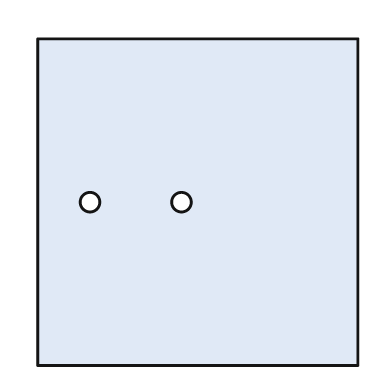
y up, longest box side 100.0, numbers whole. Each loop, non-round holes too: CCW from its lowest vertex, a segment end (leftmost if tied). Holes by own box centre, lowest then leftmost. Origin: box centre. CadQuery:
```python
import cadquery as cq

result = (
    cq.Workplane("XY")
    .moveTo(-49.0, -50.0)
    .lineTo(49.0, -50.0)
    .lineTo(49.0, 50.0)
    .lineTo(-49.0, 50.0)
    .close()
    .moveTo(-33.0, 0.0)
    .circle(3.0)
    .moveTo(-5.0, 0.0)
    .circle(3.0)
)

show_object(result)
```